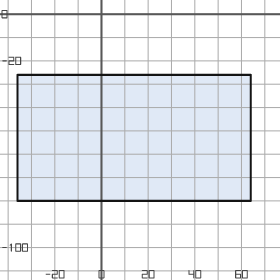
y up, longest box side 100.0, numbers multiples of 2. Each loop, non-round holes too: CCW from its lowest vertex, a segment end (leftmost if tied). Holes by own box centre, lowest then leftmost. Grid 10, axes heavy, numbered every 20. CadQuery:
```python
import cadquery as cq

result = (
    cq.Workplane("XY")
    .moveTo(-36.0, -80.0)
    .lineTo(64.0, -80.0)
    .lineTo(64.0, -26.0)
    .lineTo(-36.0, -26.0)
    .close()
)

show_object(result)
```